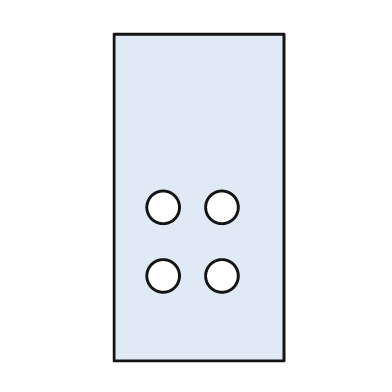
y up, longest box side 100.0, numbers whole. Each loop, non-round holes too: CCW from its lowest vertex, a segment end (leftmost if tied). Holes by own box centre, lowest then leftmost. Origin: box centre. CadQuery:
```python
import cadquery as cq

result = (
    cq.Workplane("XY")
    .moveTo(-26.0, -50.0)
    .lineTo(26.0, -50.0)
    .lineTo(26.0, 50.0)
    .lineTo(-26.0, 50.0)
    .close()
    .moveTo(-11.0, -24.0)
    .circle(5.0)
    .moveTo(7.0, -24.0)
    .circle(5.0)
    .moveTo(-11.0, -3.0)
    .circle(5.0)
    .moveTo(7.0, -3.0)
    .circle(5.0)
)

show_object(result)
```